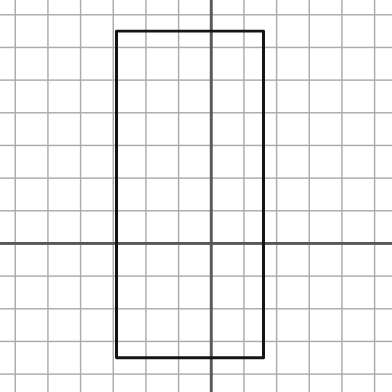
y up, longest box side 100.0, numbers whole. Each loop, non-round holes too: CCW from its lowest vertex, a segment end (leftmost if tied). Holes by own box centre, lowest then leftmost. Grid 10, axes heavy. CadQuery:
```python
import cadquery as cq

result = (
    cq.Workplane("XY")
    .moveTo(-29.0, -35.0)
    .lineTo(16.0, -35.0)
    .lineTo(16.0, 65.0)
    .lineTo(-29.0, 65.0)
    .close()
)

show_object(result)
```